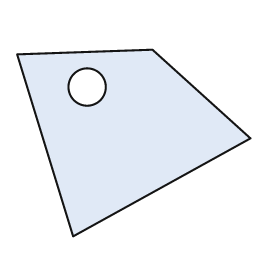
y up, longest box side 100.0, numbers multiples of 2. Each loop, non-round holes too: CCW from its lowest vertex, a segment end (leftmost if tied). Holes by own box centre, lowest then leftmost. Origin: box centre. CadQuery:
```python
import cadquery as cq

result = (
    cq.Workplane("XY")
    .moveTo(-26.0, -40.0)
    .lineTo(50.0, 2.0)
    .lineTo(8.0, 40.0)
    .lineTo(-50.0, 38.0)
    .close()
    .moveTo(-20.0, 24.0)
    .circle(8.0)
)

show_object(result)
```